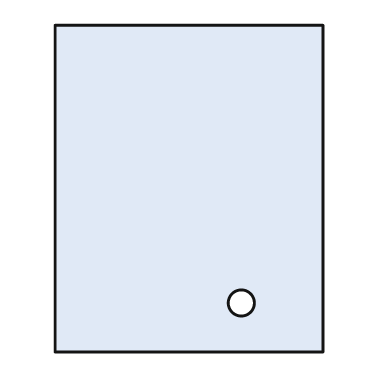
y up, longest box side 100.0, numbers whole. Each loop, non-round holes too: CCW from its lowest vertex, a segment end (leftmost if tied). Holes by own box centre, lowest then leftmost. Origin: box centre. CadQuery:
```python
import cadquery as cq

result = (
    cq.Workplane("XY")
    .moveTo(-41.0, -50.0)
    .lineTo(41.0, -50.0)
    .lineTo(41.0, 50.0)
    .lineTo(-41.0, 50.0)
    .close()
    .moveTo(16.0, -35.0)
    .circle(4.0)
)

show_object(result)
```